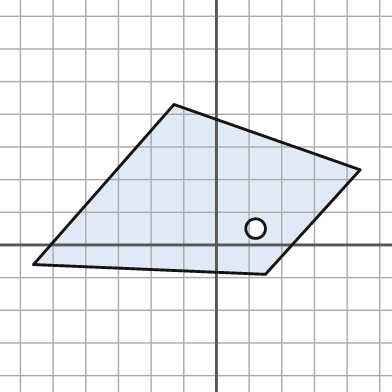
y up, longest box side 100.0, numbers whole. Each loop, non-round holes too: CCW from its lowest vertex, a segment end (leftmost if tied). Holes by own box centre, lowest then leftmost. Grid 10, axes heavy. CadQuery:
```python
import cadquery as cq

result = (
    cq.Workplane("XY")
    .moveTo(15.0, -9.0)
    .lineTo(44.0, 23.0)
    .lineTo(-13.0, 43.0)
    .lineTo(-56.0, -6.0)
    .close()
    .moveTo(12.0, 5.0)
    .circle(3.0)
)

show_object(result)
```